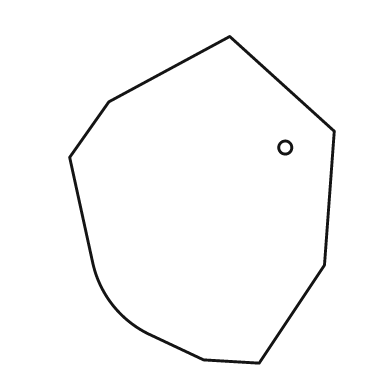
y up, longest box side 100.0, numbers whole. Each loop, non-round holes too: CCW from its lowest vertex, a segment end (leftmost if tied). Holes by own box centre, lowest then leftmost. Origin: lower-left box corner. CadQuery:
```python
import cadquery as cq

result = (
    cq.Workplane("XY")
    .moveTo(58.0, 0.0)
    .lineTo(78.0, 30.0)
    .lineTo(81.0, 71.0)
    .lineTo(49.0, 100.0)
    .lineTo(12.0, 80.0)
    .lineTo(0.0, 63.0)
    .lineTo(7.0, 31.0)
    .threePointArc((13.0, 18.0), (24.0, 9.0))
    .lineTo(41.0, 1.0)
    .close()
    .moveTo(66.0, 66.0)
    .circle(2.0)
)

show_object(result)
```